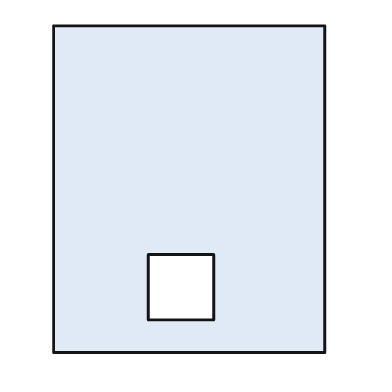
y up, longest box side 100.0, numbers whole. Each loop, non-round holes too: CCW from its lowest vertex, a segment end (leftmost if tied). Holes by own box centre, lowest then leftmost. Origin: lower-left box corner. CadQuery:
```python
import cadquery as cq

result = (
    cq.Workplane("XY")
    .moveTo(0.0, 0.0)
    .lineTo(83.0, 0.0)
    .lineTo(83.0, 100.0)
    .lineTo(0.0, 100.0)
    .close()
    .moveTo(29.0, 10.0)
    .lineTo(49.0, 10.0)
    .lineTo(49.0, 30.0)
    .lineTo(29.0, 30.0)
    .close()
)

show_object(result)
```